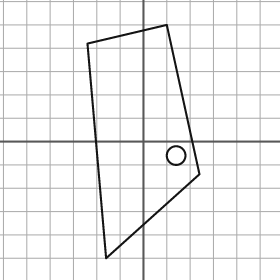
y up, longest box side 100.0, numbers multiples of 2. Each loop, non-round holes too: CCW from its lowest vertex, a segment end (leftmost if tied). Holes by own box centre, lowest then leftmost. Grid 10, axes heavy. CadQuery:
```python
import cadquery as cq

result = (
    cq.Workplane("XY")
    .moveTo(-16.0, -50.0)
    .lineTo(24.0, -14.0)
    .lineTo(10.0, 50.0)
    .lineTo(-24.0, 42.0)
    .close()
    .moveTo(14.0, -6.0)
    .circle(4.0)
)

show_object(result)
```